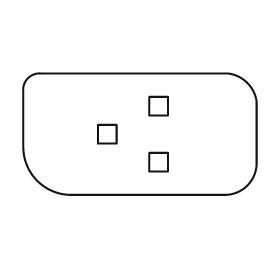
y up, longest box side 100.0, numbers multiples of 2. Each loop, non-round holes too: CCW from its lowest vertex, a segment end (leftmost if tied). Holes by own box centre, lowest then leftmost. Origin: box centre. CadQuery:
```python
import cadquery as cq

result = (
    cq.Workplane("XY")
    .moveTo(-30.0, -26.0)
    .lineTo(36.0, -26.0)
    .threePointArc((46.0, -22.0), (50.0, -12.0))
    .lineTo(50.0, 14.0)
    .threePointArc((46.0, 22.0), (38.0, 26.0))
    .lineTo(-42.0, 26.0)
    .threePointArc((-48.0, 24.0), (-50.0, 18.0))
    .lineTo(-50.0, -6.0)
    .threePointArc((-44.0, -20.0), (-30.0, -26.0))
    .close()
    .moveTo(4.0, -16.0)
    .lineTo(12.0, -16.0)
    .lineTo(12.0, -8.0)
    .lineTo(4.0, -8.0)
    .close()
    .moveTo(-18.0, -4.0)
    .lineTo(-10.0, -4.0)
    .lineTo(-10.0, 4.0)
    .lineTo(-18.0, 4.0)
    .close()
    .moveTo(4.0, 8.0)
    .lineTo(12.0, 8.0)
    .lineTo(12.0, 16.0)
    .lineTo(4.0, 16.0)
    .close()
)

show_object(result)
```